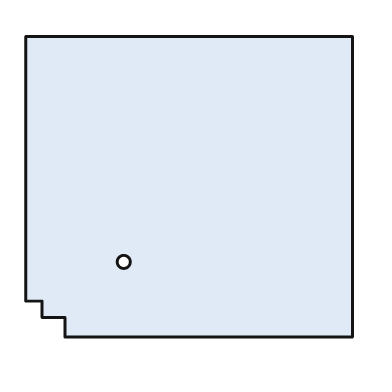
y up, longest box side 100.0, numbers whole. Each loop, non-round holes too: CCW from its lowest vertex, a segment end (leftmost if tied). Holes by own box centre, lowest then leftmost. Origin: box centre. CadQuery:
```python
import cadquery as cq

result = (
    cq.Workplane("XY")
    .moveTo(-38.0, -46.0)
    .lineTo(50.0, -46.0)
    .lineTo(50.0, 46.0)
    .lineTo(-50.0, 46.0)
    .lineTo(-50.0, -35.0)
    .lineTo(-45.0, -35.0)
    .lineTo(-45.0, -40.0)
    .lineTo(-38.0, -40.0)
    .close()
    .moveTo(-20.0, -23.0)
    .circle(2.0)
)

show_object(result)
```